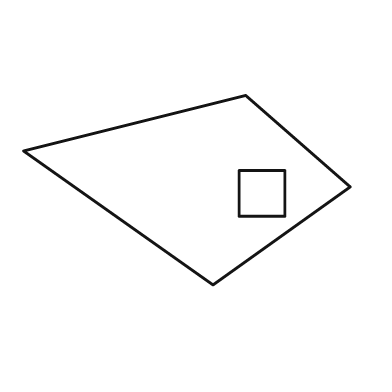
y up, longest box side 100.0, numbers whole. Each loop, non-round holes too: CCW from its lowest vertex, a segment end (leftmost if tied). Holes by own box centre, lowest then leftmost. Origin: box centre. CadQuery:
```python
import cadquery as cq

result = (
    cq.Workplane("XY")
    .moveTo(8.0, -29.0)
    .lineTo(50.0, 1.0)
    .lineTo(18.0, 29.0)
    .lineTo(-50.0, 12.0)
    .close()
    .moveTo(16.0, -8.0)
    .lineTo(30.0, -8.0)
    .lineTo(30.0, 6.0)
    .lineTo(16.0, 6.0)
    .close()
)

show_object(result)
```